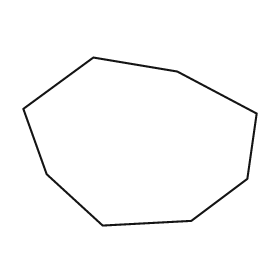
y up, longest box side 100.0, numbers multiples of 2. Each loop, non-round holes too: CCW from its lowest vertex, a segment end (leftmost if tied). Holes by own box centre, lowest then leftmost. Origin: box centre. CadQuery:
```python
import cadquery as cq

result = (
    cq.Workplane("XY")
    .moveTo(-16.0, -36.0)
    .lineTo(22.0, -34.0)
    .lineTo(46.0, -16.0)
    .lineTo(50.0, 12.0)
    .lineTo(16.0, 30.0)
    .lineTo(-20.0, 36.0)
    .lineTo(-50.0, 14.0)
    .lineTo(-40.0, -14.0)
    .close()
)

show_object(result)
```